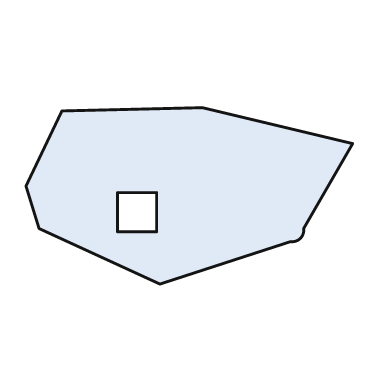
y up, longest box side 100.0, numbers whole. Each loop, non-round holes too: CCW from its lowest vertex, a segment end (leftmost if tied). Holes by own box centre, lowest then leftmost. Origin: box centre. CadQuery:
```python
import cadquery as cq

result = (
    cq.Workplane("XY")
    .moveTo(-9.0, -27.0)
    .lineTo(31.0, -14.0)
    .threePointArc((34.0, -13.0), (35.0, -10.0))
    .lineTo(50.0, 16.0)
    .lineTo(4.0, 27.0)
    .lineTo(-39.0, 26.0)
    .lineTo(-50.0, 3.0)
    .lineTo(-46.0, -10.0)
    .close()
    .moveTo(-22.0, -11.0)
    .lineTo(-10.0, -11.0)
    .lineTo(-10.0, 1.0)
    .lineTo(-22.0, 1.0)
    .close()
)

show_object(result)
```